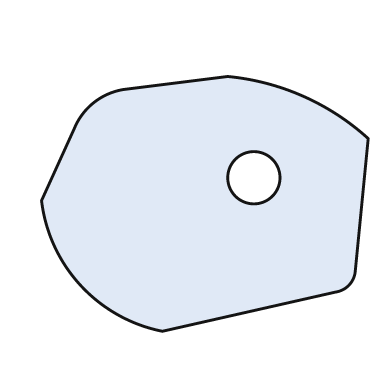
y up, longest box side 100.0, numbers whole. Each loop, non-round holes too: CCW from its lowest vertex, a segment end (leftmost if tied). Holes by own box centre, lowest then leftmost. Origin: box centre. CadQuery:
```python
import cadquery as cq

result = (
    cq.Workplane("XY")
    .moveTo(-13.0, -39.0)
    .lineTo(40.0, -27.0)
    .threePointArc((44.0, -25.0), (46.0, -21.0))
    .lineTo(50.0, 20.0)
    .threePointArc((30.0, 33.0), (7.0, 39.0))
    .lineTo(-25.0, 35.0)
    .threePointArc((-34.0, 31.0), (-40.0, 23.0))
    .lineTo(-50.0, 1.0)
    .threePointArc((-38.0, -25.0), (-13.0, -39.0))
    .close()
    .moveTo(15.0, 8.0)
    .circle(8.0)
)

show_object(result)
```